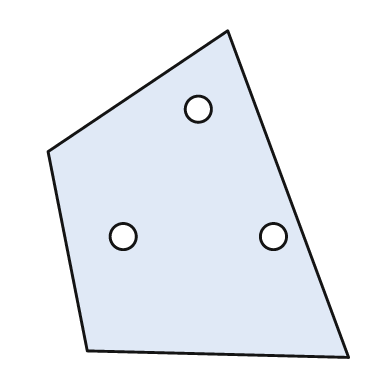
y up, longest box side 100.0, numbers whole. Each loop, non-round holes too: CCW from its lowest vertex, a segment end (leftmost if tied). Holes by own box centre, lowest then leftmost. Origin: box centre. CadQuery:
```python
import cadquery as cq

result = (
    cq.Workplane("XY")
    .moveTo(46.0, -50.0)
    .lineTo(9.0, 50.0)
    .lineTo(-46.0, 13.0)
    .lineTo(-34.0, -48.0)
    .close()
    .moveTo(-23.0, -13.0)
    .circle(4.0)
    .moveTo(23.0, -13.0)
    .circle(4.0)
    .moveTo(0.0, 26.0)
    .circle(4.0)
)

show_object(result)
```